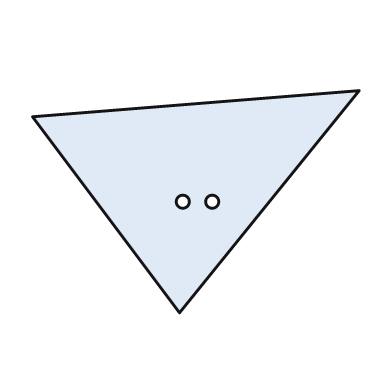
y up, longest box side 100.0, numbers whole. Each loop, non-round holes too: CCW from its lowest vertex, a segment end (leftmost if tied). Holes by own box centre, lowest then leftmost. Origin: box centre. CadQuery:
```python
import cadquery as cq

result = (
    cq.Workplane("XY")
    .moveTo(-5.0, -34.0)
    .lineTo(50.0, 34.0)
    .lineTo(-50.0, 26.0)
    .close()
    .moveTo(-4.0, 0.0)
    .circle(2.0)
    .moveTo(5.0, 0.0)
    .circle(2.0)
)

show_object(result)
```